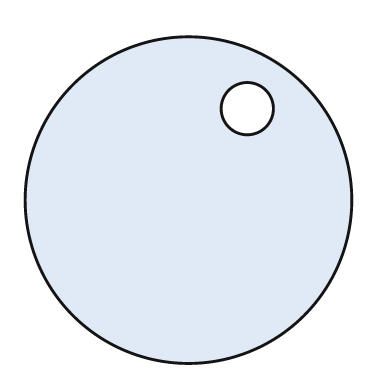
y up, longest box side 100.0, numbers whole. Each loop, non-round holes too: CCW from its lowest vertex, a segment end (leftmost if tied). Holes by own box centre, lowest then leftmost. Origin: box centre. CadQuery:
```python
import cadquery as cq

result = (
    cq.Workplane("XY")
    .moveTo(0.0, 0.0)
    .circle(50.0)
    .moveTo(18.0, 28.0)
    .circle(8.0)
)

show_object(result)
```